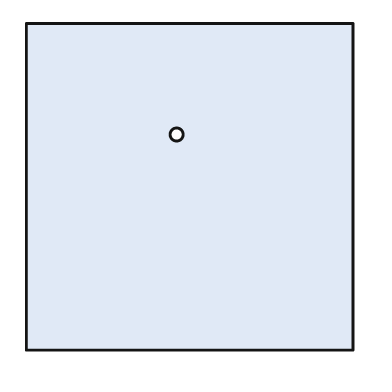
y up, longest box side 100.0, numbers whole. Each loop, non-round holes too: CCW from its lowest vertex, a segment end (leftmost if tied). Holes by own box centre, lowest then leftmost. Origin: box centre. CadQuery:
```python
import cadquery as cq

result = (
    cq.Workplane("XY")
    .moveTo(-50.0, -50.0)
    .lineTo(50.0, -50.0)
    .lineTo(50.0, 50.0)
    .lineTo(-50.0, 50.0)
    .close()
    .moveTo(-4.0, 16.0)
    .circle(2.0)
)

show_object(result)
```